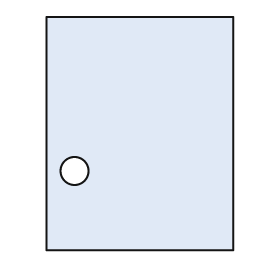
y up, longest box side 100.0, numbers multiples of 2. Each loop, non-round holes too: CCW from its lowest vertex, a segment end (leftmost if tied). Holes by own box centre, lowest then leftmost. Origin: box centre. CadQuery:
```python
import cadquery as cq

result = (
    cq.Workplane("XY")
    .moveTo(-40.0, -50.0)
    .lineTo(40.0, -50.0)
    .lineTo(40.0, 50.0)
    .lineTo(-40.0, 50.0)
    .close()
    .moveTo(-28.0, -16.0)
    .circle(6.0)
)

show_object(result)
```